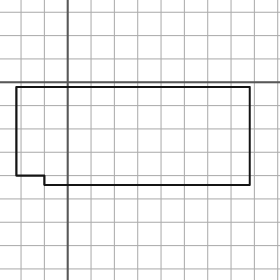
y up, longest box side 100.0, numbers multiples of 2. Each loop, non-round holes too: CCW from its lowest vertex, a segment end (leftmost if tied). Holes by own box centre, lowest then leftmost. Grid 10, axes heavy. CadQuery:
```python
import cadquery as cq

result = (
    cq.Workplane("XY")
    .moveTo(-10.0, -44.0)
    .lineTo(78.0, -44.0)
    .lineTo(78.0, -2.0)
    .lineTo(-22.0, -2.0)
    .lineTo(-22.0, -40.0)
    .lineTo(-10.0, -40.0)
    .close()
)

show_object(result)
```